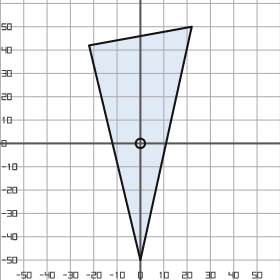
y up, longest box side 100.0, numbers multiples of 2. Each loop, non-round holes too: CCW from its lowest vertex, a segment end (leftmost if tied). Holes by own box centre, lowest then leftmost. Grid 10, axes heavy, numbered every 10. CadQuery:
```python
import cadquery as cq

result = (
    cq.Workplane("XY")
    .moveTo(0.0, -50.0)
    .lineTo(22.0, 50.0)
    .lineTo(-22.0, 42.0)
    .close()
    .moveTo(0.0, 0.0)
    .circle(2.0)
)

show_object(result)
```